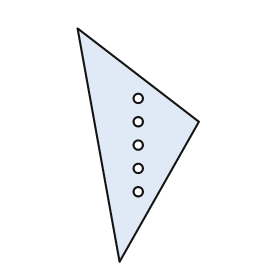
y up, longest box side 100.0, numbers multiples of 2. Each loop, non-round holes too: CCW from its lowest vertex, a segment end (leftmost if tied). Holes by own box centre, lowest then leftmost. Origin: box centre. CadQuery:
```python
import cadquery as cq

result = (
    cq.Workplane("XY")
    .moveTo(-8.0, -50.0)
    .lineTo(26.0, 10.0)
    .lineTo(-26.0, 50.0)
    .close()
    .moveTo(0.0, -20.0)
    .circle(2.0)
    .moveTo(0.0, -10.0)
    .circle(2.0)
    .moveTo(0.0, 0.0)
    .circle(2.0)
    .moveTo(0.0, 10.0)
    .circle(2.0)
    .moveTo(0.0, 20.0)
    .circle(2.0)
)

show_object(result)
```